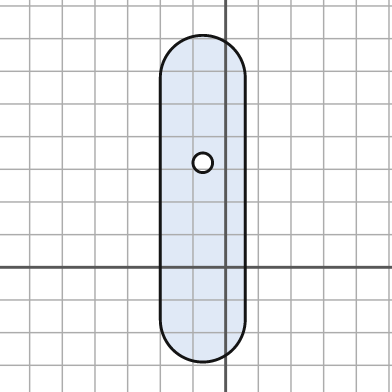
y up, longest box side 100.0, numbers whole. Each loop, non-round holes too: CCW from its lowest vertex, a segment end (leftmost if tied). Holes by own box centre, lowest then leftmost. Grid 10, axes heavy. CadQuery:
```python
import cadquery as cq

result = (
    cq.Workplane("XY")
    .moveTo(-20.0, -16.0)
    .threePointArc((-7.0, -29.0), (6.0, -16.0))
    .lineTo(6.0, 58.0)
    .threePointArc((-7.0, 71.0), (-20.0, 58.0))
    .close()
    .moveTo(-7.0, 32.0)
    .circle(3.0)
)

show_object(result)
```